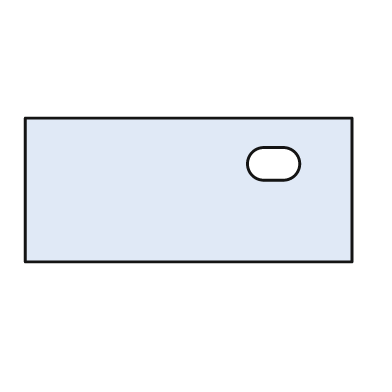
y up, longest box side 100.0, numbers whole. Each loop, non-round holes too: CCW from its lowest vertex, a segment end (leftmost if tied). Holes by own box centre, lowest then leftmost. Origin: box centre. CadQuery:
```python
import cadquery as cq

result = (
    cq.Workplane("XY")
    .moveTo(-50.0, -22.0)
    .lineTo(50.0, -22.0)
    .lineTo(50.0, 22.0)
    .lineTo(-50.0, 22.0)
    .close()
    .moveTo(23.0, 3.0)
    .lineTo(29.0, 3.0)
    .threePointArc((34.0, 8.0), (29.0, 13.0))
    .lineTo(23.0, 13.0)
    .threePointArc((18.0, 8.0), (23.0, 3.0))
    .close()
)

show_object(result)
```